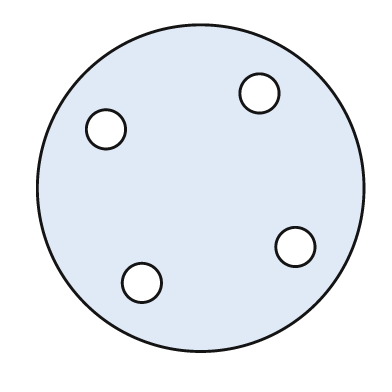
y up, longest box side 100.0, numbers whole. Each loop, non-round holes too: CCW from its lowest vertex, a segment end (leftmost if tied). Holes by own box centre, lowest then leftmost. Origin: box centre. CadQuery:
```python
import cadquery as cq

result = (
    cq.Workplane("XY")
    .moveTo(0.0, 0.0)
    .circle(50.0)
    .moveTo(-18.0, -29.0)
    .circle(6.0)
    .moveTo(29.0, -18.0)
    .circle(6.0)
    .moveTo(-29.0, 18.0)
    .circle(6.0)
    .moveTo(18.0, 29.0)
    .circle(6.0)
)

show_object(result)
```